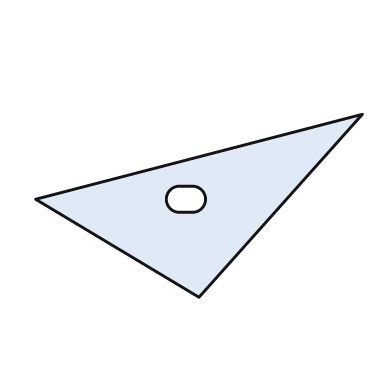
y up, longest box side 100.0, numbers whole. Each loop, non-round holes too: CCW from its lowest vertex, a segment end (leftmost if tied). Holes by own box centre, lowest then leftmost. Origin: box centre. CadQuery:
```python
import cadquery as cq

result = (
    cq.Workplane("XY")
    .moveTo(0.0, -28.0)
    .lineTo(50.0, 28.0)
    .lineTo(-50.0, 2.0)
    .close()
    .moveTo(-6.0, -2.0)
    .lineTo(-2.0, -2.0)
    .threePointArc((2.0, 2.0), (-2.0, 6.0))
    .lineTo(-6.0, 6.0)
    .threePointArc((-10.0, 2.0), (-6.0, -2.0))
    .close()
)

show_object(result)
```